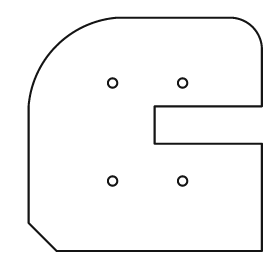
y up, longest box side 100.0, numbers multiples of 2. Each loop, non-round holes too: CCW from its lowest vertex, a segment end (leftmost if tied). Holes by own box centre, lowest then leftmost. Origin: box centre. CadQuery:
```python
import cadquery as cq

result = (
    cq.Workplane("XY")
    .moveTo(-38.0, -50.0)
    .lineTo(50.0, -50.0)
    .lineTo(50.0, -4.0)
    .lineTo(4.0, -4.0)
    .lineTo(4.0, 12.0)
    .lineTo(50.0, 12.0)
    .lineTo(50.0, 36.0)
    .threePointArc((46.0, 46.0), (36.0, 50.0))
    .lineTo(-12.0, 50.0)
    .threePointArc((-38.0, 38.0), (-50.0, 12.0))
    .lineTo(-50.0, -38.0)
    .close()
    .moveTo(-14.0, -20.0)
    .circle(2.0)
    .moveTo(16.0, -20.0)
    .circle(2.0)
    .moveTo(-14.0, 22.0)
    .circle(2.0)
    .moveTo(16.0, 22.0)
    .circle(2.0)
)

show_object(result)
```